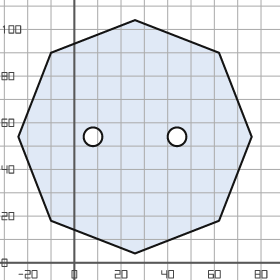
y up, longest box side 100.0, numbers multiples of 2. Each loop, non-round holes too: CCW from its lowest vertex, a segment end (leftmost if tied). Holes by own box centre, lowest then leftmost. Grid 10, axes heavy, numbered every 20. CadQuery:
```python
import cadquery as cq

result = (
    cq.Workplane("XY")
    .moveTo(26.0, 4.0)
    .lineTo(62.0, 18.0)
    .lineTo(76.0, 54.0)
    .lineTo(62.0, 90.0)
    .lineTo(26.0, 104.0)
    .lineTo(-10.0, 90.0)
    .lineTo(-24.0, 54.0)
    .lineTo(-10.0, 18.0)
    .close()
    .moveTo(8.0, 54.0)
    .circle(4.0)
    .moveTo(44.0, 54.0)
    .circle(4.0)
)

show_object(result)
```